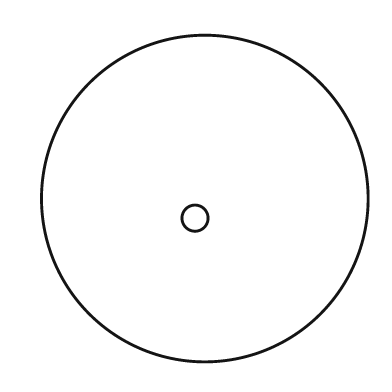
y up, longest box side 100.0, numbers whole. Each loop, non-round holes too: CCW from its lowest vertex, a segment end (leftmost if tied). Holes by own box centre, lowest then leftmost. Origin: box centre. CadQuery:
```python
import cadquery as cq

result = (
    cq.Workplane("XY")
    .moveTo(0.0, 0.0)
    .circle(50.0)
    .moveTo(-3.0, -6.0)
    .circle(4.0)
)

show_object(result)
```